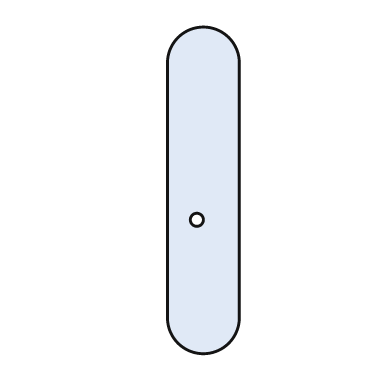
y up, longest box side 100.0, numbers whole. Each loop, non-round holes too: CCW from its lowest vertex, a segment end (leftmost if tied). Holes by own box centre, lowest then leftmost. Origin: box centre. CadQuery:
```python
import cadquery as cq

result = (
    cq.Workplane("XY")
    .moveTo(-11.0, -39.0)
    .threePointArc((0.0, -50.0), (11.0, -39.0))
    .lineTo(11.0, 39.0)
    .threePointArc((0.0, 50.0), (-11.0, 39.0))
    .close()
    .moveTo(-2.0, -9.0)
    .circle(2.0)
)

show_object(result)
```